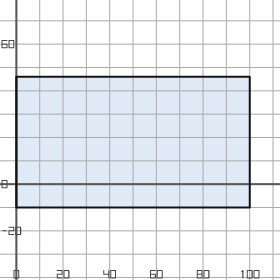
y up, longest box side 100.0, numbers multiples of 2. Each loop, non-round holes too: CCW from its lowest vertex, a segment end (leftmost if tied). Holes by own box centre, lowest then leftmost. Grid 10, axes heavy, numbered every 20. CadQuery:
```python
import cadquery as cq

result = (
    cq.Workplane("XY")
    .moveTo(0.0, -10.0)
    .lineTo(100.0, -10.0)
    .lineTo(100.0, 46.0)
    .lineTo(0.0, 46.0)
    .close()
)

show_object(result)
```